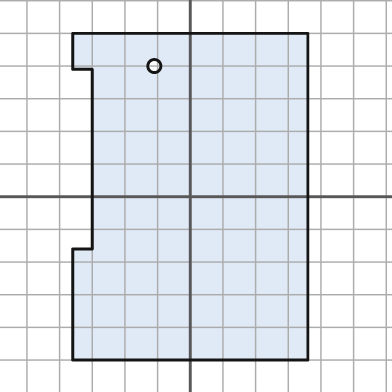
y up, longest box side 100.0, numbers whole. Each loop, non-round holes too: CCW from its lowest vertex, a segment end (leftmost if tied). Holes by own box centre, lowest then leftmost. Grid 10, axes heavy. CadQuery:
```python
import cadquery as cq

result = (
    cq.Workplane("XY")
    .moveTo(-36.0, -50.0)
    .lineTo(36.0, -50.0)
    .lineTo(36.0, 50.0)
    .lineTo(-36.0, 50.0)
    .lineTo(-36.0, 39.0)
    .lineTo(-30.0, 39.0)
    .lineTo(-30.0, -16.0)
    .lineTo(-36.0, -16.0)
    .close()
    .moveTo(-11.0, 40.0)
    .circle(2.0)
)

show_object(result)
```